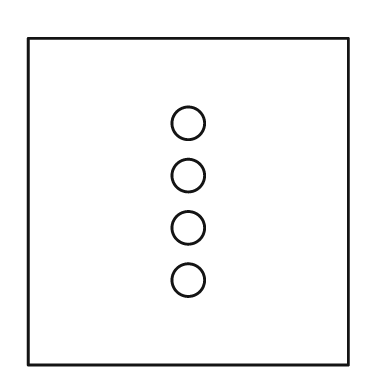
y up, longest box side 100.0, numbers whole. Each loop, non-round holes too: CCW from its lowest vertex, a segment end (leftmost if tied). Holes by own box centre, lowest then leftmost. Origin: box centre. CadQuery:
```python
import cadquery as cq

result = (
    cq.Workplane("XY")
    .moveTo(-49.0, -50.0)
    .lineTo(49.0, -50.0)
    .lineTo(49.0, 50.0)
    .lineTo(-49.0, 50.0)
    .close()
    .moveTo(0.0, -24.0)
    .circle(5.0)
    .moveTo(0.0, -8.0)
    .circle(5.0)
    .moveTo(0.0, 8.0)
    .circle(5.0)
    .moveTo(0.0, 24.0)
    .circle(5.0)
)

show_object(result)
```